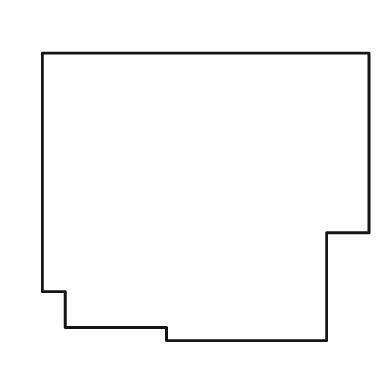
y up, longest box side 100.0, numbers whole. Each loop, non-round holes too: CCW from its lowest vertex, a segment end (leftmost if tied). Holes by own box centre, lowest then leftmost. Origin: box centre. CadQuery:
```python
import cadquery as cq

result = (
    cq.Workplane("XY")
    .moveTo(-12.0, -44.0)
    .lineTo(37.0, -44.0)
    .lineTo(37.0, -11.0)
    .lineTo(50.0, -11.0)
    .lineTo(50.0, 44.0)
    .lineTo(-50.0, 44.0)
    .lineTo(-50.0, -29.0)
    .lineTo(-43.0, -29.0)
    .lineTo(-43.0, -40.0)
    .lineTo(-12.0, -40.0)
    .close()
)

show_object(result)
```